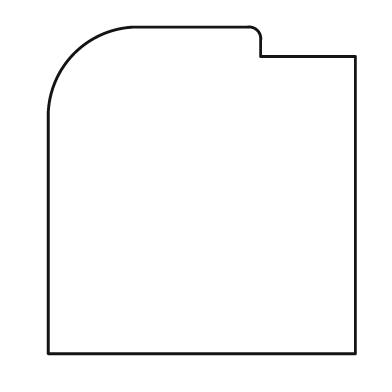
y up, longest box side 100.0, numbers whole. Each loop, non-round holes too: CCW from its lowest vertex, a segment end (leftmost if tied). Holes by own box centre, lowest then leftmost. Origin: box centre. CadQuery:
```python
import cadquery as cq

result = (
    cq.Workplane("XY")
    .moveTo(-47.0, -50.0)
    .lineTo(47.0, -50.0)
    .lineTo(47.0, 41.0)
    .lineTo(18.0, 41.0)
    .lineTo(18.0, 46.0)
    .threePointArc((17.0, 49.0), (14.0, 50.0))
    .lineTo(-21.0, 50.0)
    .threePointArc((-39.0, 42.0), (-47.0, 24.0))
    .close()
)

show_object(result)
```